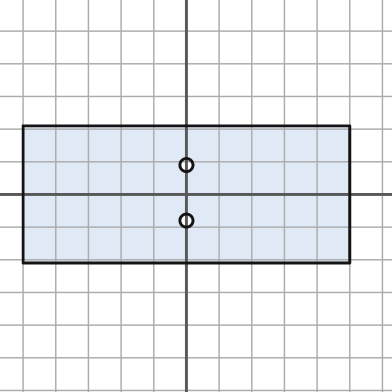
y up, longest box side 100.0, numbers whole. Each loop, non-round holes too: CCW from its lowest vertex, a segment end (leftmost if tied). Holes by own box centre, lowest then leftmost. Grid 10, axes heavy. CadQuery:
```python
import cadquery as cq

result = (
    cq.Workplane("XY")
    .moveTo(-50.0, -21.0)
    .lineTo(50.0, -21.0)
    .lineTo(50.0, 21.0)
    .lineTo(-50.0, 21.0)
    .close()
    .moveTo(0.0, -8.0)
    .circle(2.0)
    .moveTo(0.0, 9.0)
    .circle(2.0)
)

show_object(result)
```